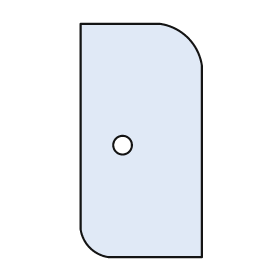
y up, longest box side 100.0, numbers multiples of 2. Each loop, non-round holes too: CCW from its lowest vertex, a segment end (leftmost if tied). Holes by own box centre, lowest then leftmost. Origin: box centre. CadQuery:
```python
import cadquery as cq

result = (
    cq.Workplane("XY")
    .moveTo(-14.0, -50.0)
    .lineTo(26.0, -50.0)
    .lineTo(26.0, 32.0)
    .threePointArc((20.0, 44.0), (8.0, 50.0))
    .lineTo(-26.0, 50.0)
    .lineTo(-26.0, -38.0)
    .threePointArc((-22.0, -46.0), (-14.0, -50.0))
    .close()
    .moveTo(-8.0, -2.0)
    .circle(4.0)
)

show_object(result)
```